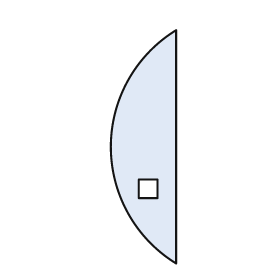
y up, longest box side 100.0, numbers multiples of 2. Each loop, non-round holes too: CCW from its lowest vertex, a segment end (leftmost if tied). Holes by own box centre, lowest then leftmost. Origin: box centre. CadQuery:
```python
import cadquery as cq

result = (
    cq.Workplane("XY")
    .moveTo(14.0, -50.0)
    .lineTo(14.0, 50.0)
    .threePointArc((-14.0, 0.0), (14.0, -50.0))
    .close()
    .moveTo(-2.0, -22.0)
    .lineTo(6.0, -22.0)
    .lineTo(6.0, -14.0)
    .lineTo(-2.0, -14.0)
    .close()
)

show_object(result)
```